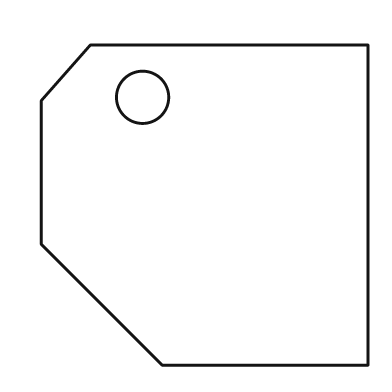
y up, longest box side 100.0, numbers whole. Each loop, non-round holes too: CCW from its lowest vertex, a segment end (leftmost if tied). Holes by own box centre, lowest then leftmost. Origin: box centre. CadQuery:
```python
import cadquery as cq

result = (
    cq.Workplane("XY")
    .moveTo(-13.0, -49.0)
    .lineTo(50.0, -49.0)
    .lineTo(50.0, 49.0)
    .lineTo(-35.0, 49.0)
    .lineTo(-50.0, 32.0)
    .lineTo(-50.0, -12.0)
    .close()
    .moveTo(-19.0, 33.0)
    .circle(8.0)
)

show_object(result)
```